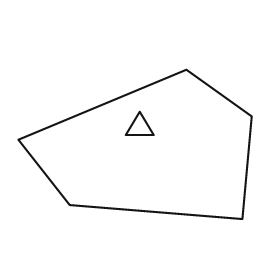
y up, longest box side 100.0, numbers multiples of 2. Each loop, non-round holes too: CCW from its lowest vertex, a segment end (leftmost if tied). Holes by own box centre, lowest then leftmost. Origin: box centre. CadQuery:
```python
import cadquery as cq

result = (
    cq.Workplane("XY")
    .moveTo(46.0, -32.0)
    .lineTo(50.0, 12.0)
    .lineTo(22.0, 32.0)
    .lineTo(-50.0, 2.0)
    .lineTo(-28.0, -26.0)
    .close()
    .moveTo(-4.0, 4.0)
    .lineTo(8.0, 4.0)
    .lineTo(2.0, 14.0)
    .close()
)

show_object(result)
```